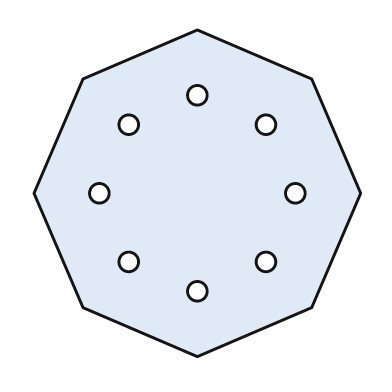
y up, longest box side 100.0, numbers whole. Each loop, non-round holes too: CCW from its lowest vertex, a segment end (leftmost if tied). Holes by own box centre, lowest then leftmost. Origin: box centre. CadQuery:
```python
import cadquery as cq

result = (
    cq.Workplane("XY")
    .moveTo(0.0, -50.0)
    .lineTo(35.0, -35.0)
    .lineTo(50.0, 0.0)
    .lineTo(35.0, 35.0)
    .lineTo(0.0, 50.0)
    .lineTo(-35.0, 35.0)
    .lineTo(-50.0, 0.0)
    .lineTo(-35.0, -35.0)
    .close()
    .moveTo(0.0, -30.0)
    .circle(3.0)
    .moveTo(-21.0, -21.0)
    .circle(3.0)
    .moveTo(21.0, -21.0)
    .circle(3.0)
    .moveTo(-30.0, 0.0)
    .circle(3.0)
    .moveTo(30.0, 0.0)
    .circle(3.0)
    .moveTo(-21.0, 21.0)
    .circle(3.0)
    .moveTo(21.0, 21.0)
    .circle(3.0)
    .moveTo(0.0, 30.0)
    .circle(3.0)
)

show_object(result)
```